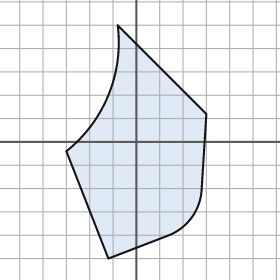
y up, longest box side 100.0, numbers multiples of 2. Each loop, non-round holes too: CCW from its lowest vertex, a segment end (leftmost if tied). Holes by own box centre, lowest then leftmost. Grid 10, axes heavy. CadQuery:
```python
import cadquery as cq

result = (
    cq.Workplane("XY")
    .moveTo(-12.0, -50.0)
    .lineTo(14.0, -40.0)
    .threePointArc((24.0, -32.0), (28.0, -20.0))
    .lineTo(30.0, 12.0)
    .lineTo(-8.0, 50.0)
    .threePointArc((-12.0, 20.0), (-30.0, -4.0))
    .close()
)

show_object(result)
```